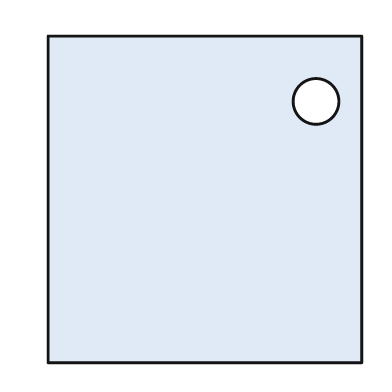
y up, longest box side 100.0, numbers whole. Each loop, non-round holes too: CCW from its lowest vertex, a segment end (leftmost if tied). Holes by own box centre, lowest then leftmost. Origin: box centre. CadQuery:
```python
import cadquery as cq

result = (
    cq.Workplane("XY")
    .moveTo(-48.0, -50.0)
    .lineTo(48.0, -50.0)
    .lineTo(48.0, 50.0)
    .lineTo(-48.0, 50.0)
    .close()
    .moveTo(34.0, 30.0)
    .circle(7.0)
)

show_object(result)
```